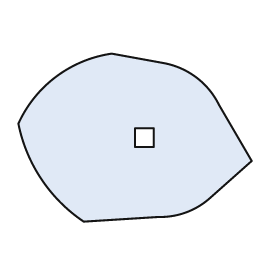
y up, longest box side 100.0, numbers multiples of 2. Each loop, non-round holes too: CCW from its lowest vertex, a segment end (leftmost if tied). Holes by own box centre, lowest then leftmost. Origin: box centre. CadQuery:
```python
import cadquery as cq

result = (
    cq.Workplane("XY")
    .moveTo(-22.0, -36.0)
    .lineTo(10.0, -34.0)
    .threePointArc((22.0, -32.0), (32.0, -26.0))
    .lineTo(50.0, -10.0)
    .lineTo(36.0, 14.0)
    .threePointArc((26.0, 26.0), (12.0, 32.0))
    .lineTo(-10.0, 36.0)
    .threePointArc((-34.0, 26.0), (-50.0, 6.0))
    .threePointArc((-40.0, -18.0), (-22.0, -36.0))
    .close()
    .moveTo(0.0, -4.0)
    .lineTo(8.0, -4.0)
    .lineTo(8.0, 4.0)
    .lineTo(0.0, 4.0)
    .close()
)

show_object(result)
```